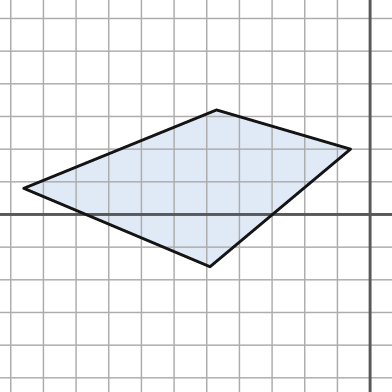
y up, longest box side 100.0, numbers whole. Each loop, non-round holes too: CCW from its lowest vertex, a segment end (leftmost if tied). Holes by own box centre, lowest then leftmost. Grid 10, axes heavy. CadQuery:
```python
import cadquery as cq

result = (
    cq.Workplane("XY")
    .moveTo(-49.0, -16.0)
    .lineTo(-6.0, 20.0)
    .lineTo(-47.0, 32.0)
    .lineTo(-106.0, 8.0)
    .close()
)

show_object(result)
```